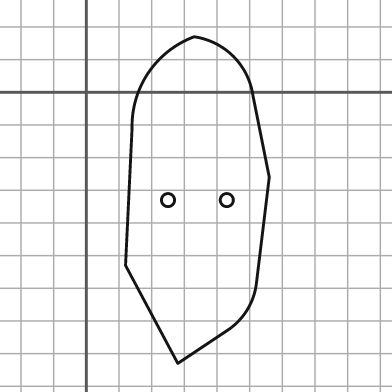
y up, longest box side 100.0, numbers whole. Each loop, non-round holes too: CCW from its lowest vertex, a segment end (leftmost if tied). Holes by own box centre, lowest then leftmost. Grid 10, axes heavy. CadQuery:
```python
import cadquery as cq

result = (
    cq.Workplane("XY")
    .moveTo(28.0, -83.0)
    .lineTo(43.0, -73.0)
    .threePointArc((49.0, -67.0), (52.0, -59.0))
    .lineTo(56.0, -26.0)
    .lineTo(51.0, -1.0)
    .threePointArc((45.0, 11.0), (33.0, 17.0))
    .threePointArc((19.0, 6.0), (14.0, -11.0))
    .lineTo(12.0, -53.0)
    .close()
    .moveTo(25.0, -33.0)
    .circle(2.0)
    .moveTo(43.0, -33.0)
    .circle(2.0)
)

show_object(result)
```